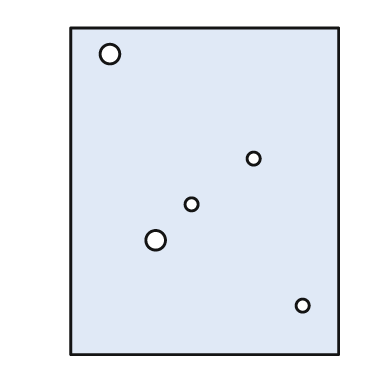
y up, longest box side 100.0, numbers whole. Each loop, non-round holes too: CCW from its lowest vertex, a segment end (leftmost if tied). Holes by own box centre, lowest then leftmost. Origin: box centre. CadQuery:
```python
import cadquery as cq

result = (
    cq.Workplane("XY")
    .moveTo(-41.0, -50.0)
    .lineTo(41.0, -50.0)
    .lineTo(41.0, 50.0)
    .lineTo(-41.0, 50.0)
    .close()
    .moveTo(30.0, -35.0)
    .circle(2.0)
    .moveTo(-15.0, -15.0)
    .circle(3.0)
    .moveTo(-4.0, -4.0)
    .circle(2.0)
    .moveTo(15.0, 10.0)
    .circle(2.0)
    .moveTo(-29.0, 42.0)
    .circle(3.0)
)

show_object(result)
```